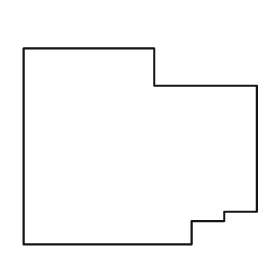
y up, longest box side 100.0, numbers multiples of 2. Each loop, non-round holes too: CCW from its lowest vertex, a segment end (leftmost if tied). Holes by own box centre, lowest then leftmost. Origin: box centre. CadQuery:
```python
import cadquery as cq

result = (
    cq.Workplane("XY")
    .moveTo(-50.0, -42.0)
    .lineTo(22.0, -42.0)
    .lineTo(22.0, -32.0)
    .lineTo(36.0, -32.0)
    .lineTo(36.0, -28.0)
    .lineTo(50.0, -28.0)
    .lineTo(50.0, 26.0)
    .lineTo(6.0, 26.0)
    .lineTo(6.0, 42.0)
    .lineTo(-50.0, 42.0)
    .close()
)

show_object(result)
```